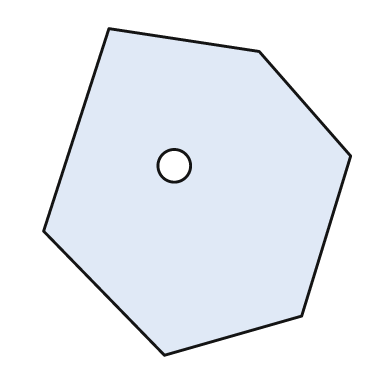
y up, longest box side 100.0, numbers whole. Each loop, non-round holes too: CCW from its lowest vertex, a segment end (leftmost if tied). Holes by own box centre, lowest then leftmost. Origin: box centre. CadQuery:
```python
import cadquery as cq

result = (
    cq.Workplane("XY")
    .moveTo(-10.0, -50.0)
    .lineTo(32.0, -38.0)
    .lineTo(47.0, 11.0)
    .lineTo(19.0, 43.0)
    .lineTo(-27.0, 50.0)
    .lineTo(-47.0, -12.0)
    .close()
    .moveTo(-7.0, 8.0)
    .circle(5.0)
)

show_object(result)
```